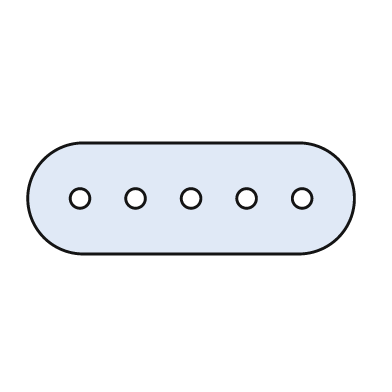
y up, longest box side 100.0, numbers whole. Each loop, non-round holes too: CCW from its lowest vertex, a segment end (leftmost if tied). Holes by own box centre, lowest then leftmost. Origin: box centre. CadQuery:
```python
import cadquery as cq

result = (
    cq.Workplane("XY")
    .moveTo(-33.0, -17.0)
    .lineTo(33.0, -17.0)
    .threePointArc((50.0, 0.0), (33.0, 17.0))
    .lineTo(-33.0, 17.0)
    .threePointArc((-50.0, 0.0), (-33.0, -17.0))
    .close()
    .moveTo(-34.0, 0.0)
    .circle(3.0)
    .moveTo(-17.0, 0.0)
    .circle(3.0)
    .moveTo(0.0, 0.0)
    .circle(3.0)
    .moveTo(17.0, 0.0)
    .circle(3.0)
    .moveTo(34.0, 0.0)
    .circle(3.0)
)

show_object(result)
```